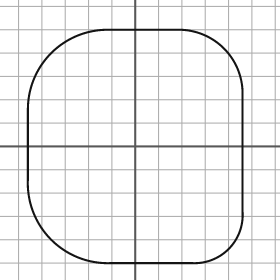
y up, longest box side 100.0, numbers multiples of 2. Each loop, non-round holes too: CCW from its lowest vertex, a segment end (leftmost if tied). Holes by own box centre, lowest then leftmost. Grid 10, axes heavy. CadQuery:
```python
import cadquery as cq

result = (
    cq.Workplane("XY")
    .moveTo(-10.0, -50.0)
    .lineTo(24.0, -50.0)
    .threePointArc((40.0, -44.0), (46.0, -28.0))
    .lineTo(46.0, 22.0)
    .threePointArc((38.0, 42.0), (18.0, 50.0))
    .lineTo(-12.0, 50.0)
    .threePointArc((-36.0, 40.0), (-46.0, 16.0))
    .lineTo(-46.0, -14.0)
    .threePointArc((-36.0, -40.0), (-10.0, -50.0))
    .close()
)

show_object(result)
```